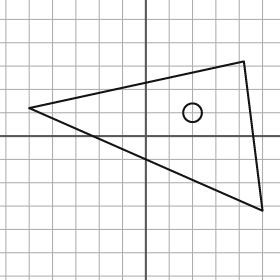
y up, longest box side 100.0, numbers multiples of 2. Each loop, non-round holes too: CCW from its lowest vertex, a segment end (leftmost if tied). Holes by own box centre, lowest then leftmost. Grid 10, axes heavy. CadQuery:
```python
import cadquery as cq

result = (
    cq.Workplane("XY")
    .moveTo(50.0, -32.0)
    .lineTo(42.0, 32.0)
    .lineTo(-50.0, 12.0)
    .close()
    .moveTo(20.0, 10.0)
    .circle(4.0)
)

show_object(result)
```